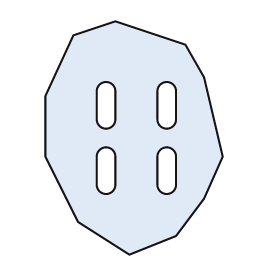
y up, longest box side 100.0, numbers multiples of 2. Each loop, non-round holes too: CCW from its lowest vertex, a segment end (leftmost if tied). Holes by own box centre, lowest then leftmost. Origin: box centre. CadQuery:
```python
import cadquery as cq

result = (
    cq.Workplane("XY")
    .moveTo(-2.0, -50.0)
    .lineTo(18.0, -42.0)
    .lineTo(30.0, -26.0)
    .lineTo(38.0, -8.0)
    .lineTo(30.0, 26.0)
    .lineTo(22.0, 40.0)
    .lineTo(-8.0, 50.0)
    .lineTo(-26.0, 44.0)
    .lineTo(-38.0, 18.0)
    .lineTo(-38.0, -8.0)
    .lineTo(-24.0, -36.0)
    .close()
    .moveTo(-16.0, -20.0)
    .threePointArc((-12.0, -24.0), (-8.0, -20.0))
    .lineTo(-8.0, -8.0)
    .threePointArc((-12.0, -4.0), (-16.0, -8.0))
    .close()
    .moveTo(10.0, -20.0)
    .threePointArc((14.0, -24.0), (18.0, -20.0))
    .lineTo(18.0, -8.0)
    .threePointArc((14.0, -4.0), (10.0, -8.0))
    .close()
    .moveTo(-16.0, 8.0)
    .threePointArc((-12.0, 4.0), (-8.0, 8.0))
    .lineTo(-8.0, 20.0)
    .threePointArc((-12.0, 24.0), (-16.0, 20.0))
    .close()
    .moveTo(10.0, 8.0)
    .threePointArc((14.0, 4.0), (18.0, 8.0))
    .lineTo(18.0, 20.0)
    .threePointArc((14.0, 24.0), (10.0, 20.0))
    .close()
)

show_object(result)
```